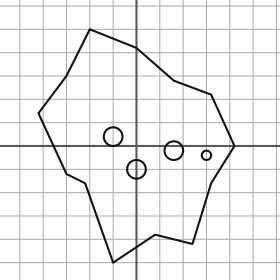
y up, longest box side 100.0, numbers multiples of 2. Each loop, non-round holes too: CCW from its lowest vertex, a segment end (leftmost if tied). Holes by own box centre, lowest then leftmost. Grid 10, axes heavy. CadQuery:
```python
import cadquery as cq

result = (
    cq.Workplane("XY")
    .moveTo(-10.0, -50.0)
    .lineTo(8.0, -38.0)
    .lineTo(24.0, -42.0)
    .lineTo(32.0, -16.0)
    .lineTo(42.0, 0.0)
    .lineTo(32.0, 22.0)
    .lineTo(16.0, 28.0)
    .lineTo(0.0, 42.0)
    .lineTo(-20.0, 50.0)
    .lineTo(-30.0, 30.0)
    .lineTo(-42.0, 14.0)
    .lineTo(-30.0, -12.0)
    .lineTo(-22.0, -16.0)
    .close()
    .moveTo(0.0, -10.0)
    .circle(4.0)
    .moveTo(30.0, -4.0)
    .circle(2.0)
    .moveTo(16.0, -2.0)
    .circle(4.0)
    .moveTo(-10.0, 4.0)
    .circle(4.0)
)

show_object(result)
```